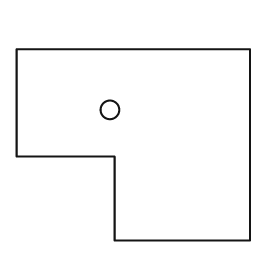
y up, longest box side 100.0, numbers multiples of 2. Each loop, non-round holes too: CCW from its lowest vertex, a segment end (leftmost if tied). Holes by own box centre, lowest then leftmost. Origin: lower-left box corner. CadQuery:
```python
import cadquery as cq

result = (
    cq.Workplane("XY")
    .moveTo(42.0, 0.0)
    .lineTo(100.0, 0.0)
    .lineTo(100.0, 82.0)
    .lineTo(0.0, 82.0)
    .lineTo(0.0, 36.0)
    .lineTo(42.0, 36.0)
    .close()
    .moveTo(40.0, 56.0)
    .circle(4.0)
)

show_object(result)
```